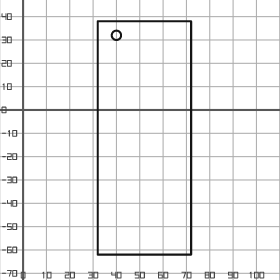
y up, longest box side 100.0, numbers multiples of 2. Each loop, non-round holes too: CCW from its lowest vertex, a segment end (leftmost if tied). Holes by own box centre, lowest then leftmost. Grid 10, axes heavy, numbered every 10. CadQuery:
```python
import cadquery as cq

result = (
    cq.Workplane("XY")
    .moveTo(32.0, -62.0)
    .lineTo(72.0, -62.0)
    .lineTo(72.0, 38.0)
    .lineTo(32.0, 38.0)
    .close()
    .moveTo(40.0, 32.0)
    .circle(2.0)
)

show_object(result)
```